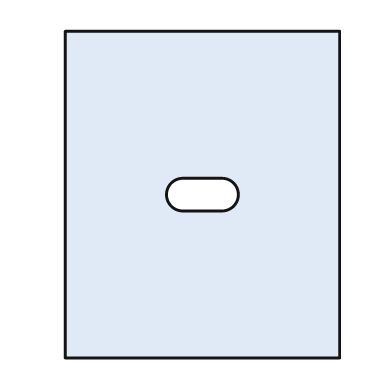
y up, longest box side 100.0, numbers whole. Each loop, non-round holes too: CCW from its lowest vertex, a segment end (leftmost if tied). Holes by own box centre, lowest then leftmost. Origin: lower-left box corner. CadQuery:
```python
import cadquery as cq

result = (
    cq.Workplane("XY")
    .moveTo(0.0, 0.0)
    .lineTo(84.0, 0.0)
    .lineTo(84.0, 100.0)
    .lineTo(0.0, 100.0)
    .close()
    .moveTo(36.0, 45.0)
    .lineTo(48.0, 45.0)
    .threePointArc((53.0, 50.0), (48.0, 55.0))
    .lineTo(36.0, 55.0)
    .threePointArc((31.0, 50.0), (36.0, 45.0))
    .close()
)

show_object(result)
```